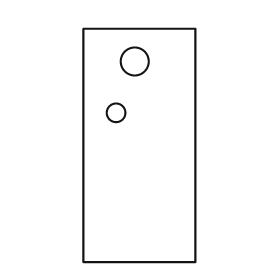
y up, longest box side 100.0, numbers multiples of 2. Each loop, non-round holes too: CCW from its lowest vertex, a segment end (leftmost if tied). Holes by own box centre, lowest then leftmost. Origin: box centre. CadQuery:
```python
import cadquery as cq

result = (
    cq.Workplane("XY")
    .moveTo(-24.0, -50.0)
    .lineTo(24.0, -50.0)
    .lineTo(24.0, 50.0)
    .lineTo(-24.0, 50.0)
    .close()
    .moveTo(-10.0, 14.0)
    .circle(4.0)
    .moveTo(-2.0, 36.0)
    .circle(6.0)
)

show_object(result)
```